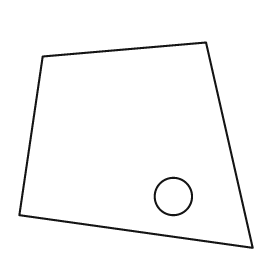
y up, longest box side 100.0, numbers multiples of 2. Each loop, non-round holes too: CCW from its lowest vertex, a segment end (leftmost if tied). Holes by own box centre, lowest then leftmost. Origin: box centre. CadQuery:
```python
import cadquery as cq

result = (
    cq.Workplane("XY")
    .moveTo(50.0, -44.0)
    .lineTo(30.0, 44.0)
    .lineTo(-40.0, 38.0)
    .lineTo(-50.0, -30.0)
    .close()
    .moveTo(16.0, -22.0)
    .circle(8.0)
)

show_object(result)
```